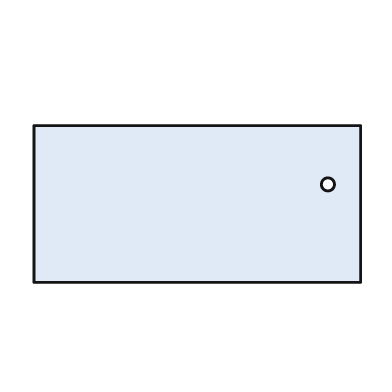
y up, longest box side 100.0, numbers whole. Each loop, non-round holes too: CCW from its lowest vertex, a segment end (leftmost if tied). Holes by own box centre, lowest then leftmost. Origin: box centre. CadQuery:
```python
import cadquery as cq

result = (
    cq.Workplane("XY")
    .moveTo(-50.0, -24.0)
    .lineTo(50.0, -24.0)
    .lineTo(50.0, 24.0)
    .lineTo(-50.0, 24.0)
    .close()
    .moveTo(40.0, 6.0)
    .circle(2.0)
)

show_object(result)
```